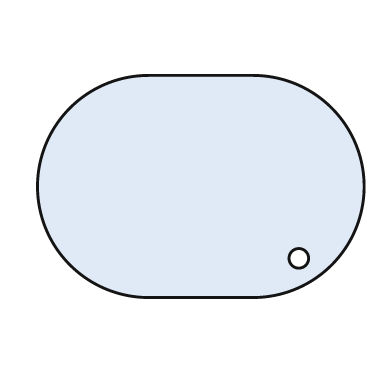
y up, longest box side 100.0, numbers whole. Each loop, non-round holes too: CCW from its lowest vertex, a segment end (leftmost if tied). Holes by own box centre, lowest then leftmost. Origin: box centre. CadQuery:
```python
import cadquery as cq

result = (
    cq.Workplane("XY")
    .moveTo(-16.0, -34.0)
    .lineTo(16.0, -34.0)
    .threePointArc((50.0, 0.0), (16.0, 34.0))
    .lineTo(-16.0, 34.0)
    .threePointArc((-50.0, 0.0), (-16.0, -34.0))
    .close()
    .moveTo(30.0, -22.0)
    .circle(3.0)
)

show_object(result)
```